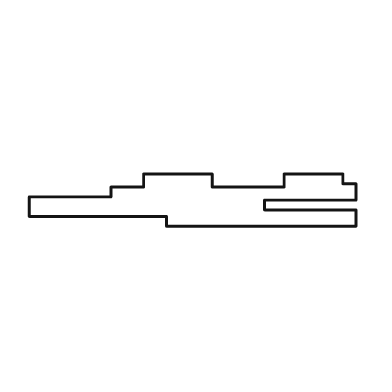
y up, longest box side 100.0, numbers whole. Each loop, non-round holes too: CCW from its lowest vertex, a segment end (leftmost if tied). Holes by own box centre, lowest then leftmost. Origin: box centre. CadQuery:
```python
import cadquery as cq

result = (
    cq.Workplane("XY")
    .moveTo(-8.0, -8.0)
    .lineTo(50.0, -8.0)
    .lineTo(50.0, -3.0)
    .lineTo(22.0, -3.0)
    .lineTo(22.0, 0.0)
    .lineTo(50.0, 0.0)
    .lineTo(50.0, 5.0)
    .lineTo(46.0, 5.0)
    .lineTo(46.0, 8.0)
    .lineTo(28.0, 8.0)
    .lineTo(28.0, 4.0)
    .lineTo(6.0, 4.0)
    .lineTo(6.0, 8.0)
    .lineTo(-15.0, 8.0)
    .lineTo(-15.0, 4.0)
    .lineTo(-25.0, 4.0)
    .lineTo(-25.0, 1.0)
    .lineTo(-50.0, 1.0)
    .lineTo(-50.0, -5.0)
    .lineTo(-8.0, -5.0)
    .close()
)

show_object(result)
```